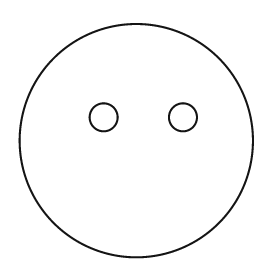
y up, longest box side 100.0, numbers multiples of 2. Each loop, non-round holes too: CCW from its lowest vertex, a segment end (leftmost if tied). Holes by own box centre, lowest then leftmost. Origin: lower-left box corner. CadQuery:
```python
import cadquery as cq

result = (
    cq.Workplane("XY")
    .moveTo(50.0, 50.0)
    .circle(50.0)
    .moveTo(36.0, 60.0)
    .circle(6.0)
    .moveTo(70.0, 60.0)
    .circle(6.0)
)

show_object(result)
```